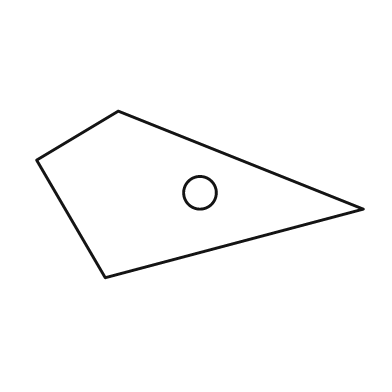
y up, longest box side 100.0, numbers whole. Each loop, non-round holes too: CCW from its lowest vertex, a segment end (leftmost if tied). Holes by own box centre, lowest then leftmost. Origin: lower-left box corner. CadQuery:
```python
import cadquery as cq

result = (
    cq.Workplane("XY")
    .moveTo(21.0, 0.0)
    .lineTo(100.0, 21.0)
    .lineTo(25.0, 51.0)
    .lineTo(0.0, 36.0)
    .close()
    .moveTo(50.0, 26.0)
    .circle(5.0)
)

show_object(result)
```